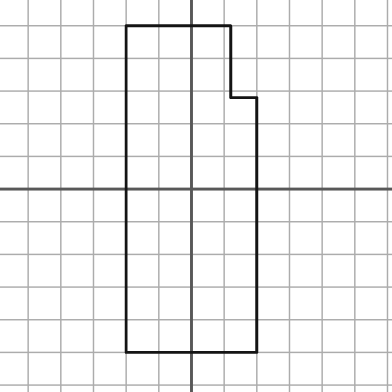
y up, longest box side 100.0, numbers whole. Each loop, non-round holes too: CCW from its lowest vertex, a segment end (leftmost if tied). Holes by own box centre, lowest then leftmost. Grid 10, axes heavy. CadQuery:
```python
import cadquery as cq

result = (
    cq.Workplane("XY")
    .moveTo(-20.0, -50.0)
    .lineTo(20.0, -50.0)
    .lineTo(20.0, 28.0)
    .lineTo(12.0, 28.0)
    .lineTo(12.0, 50.0)
    .lineTo(-20.0, 50.0)
    .close()
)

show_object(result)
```